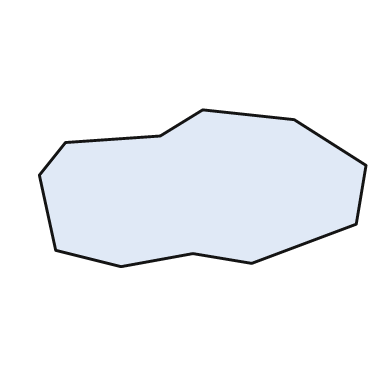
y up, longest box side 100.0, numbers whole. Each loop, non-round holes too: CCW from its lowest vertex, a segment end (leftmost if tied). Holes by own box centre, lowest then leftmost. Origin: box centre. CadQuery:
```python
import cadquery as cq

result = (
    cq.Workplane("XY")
    .moveTo(-25.0, -24.0)
    .lineTo(-3.0, -20.0)
    .lineTo(15.0, -23.0)
    .lineTo(47.0, -11.0)
    .lineTo(50.0, 7.0)
    .lineTo(28.0, 21.0)
    .lineTo(0.0, 24.0)
    .lineTo(-13.0, 16.0)
    .lineTo(-42.0, 14.0)
    .lineTo(-50.0, 4.0)
    .lineTo(-45.0, -19.0)
    .close()
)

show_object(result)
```